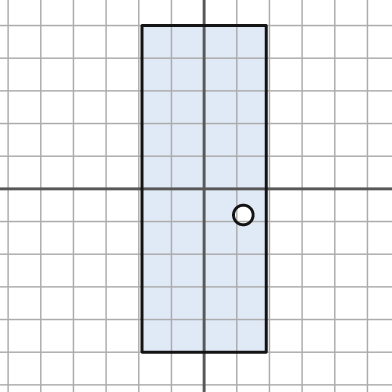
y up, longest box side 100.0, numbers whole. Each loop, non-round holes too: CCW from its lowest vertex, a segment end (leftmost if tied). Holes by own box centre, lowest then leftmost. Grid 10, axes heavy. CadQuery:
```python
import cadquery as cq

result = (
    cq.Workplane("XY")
    .moveTo(-19.0, -50.0)
    .lineTo(19.0, -50.0)
    .lineTo(19.0, 50.0)
    .lineTo(-19.0, 50.0)
    .close()
    .moveTo(12.0, -8.0)
    .circle(3.0)
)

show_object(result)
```